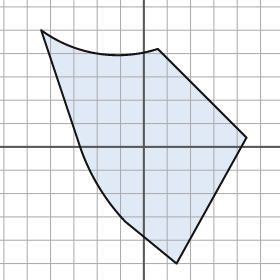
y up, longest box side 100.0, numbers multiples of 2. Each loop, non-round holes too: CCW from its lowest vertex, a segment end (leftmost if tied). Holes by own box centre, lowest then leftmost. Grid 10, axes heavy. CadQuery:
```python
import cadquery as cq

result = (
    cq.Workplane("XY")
    .moveTo(14.0, -50.0)
    .lineTo(44.0, 4.0)
    .lineTo(6.0, 42.0)
    .threePointArc((-20.0, 40.0), (-44.0, 50.0))
    .lineTo(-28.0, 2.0)
    .threePointArc((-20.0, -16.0), (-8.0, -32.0))
    .close()
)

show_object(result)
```